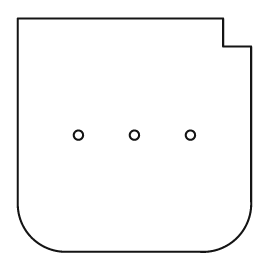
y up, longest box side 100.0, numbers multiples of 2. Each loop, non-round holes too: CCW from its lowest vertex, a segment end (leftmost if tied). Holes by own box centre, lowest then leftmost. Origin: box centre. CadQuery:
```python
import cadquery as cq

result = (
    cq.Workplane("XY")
    .moveTo(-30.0, -50.0)
    .lineTo(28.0, -50.0)
    .threePointArc((44.0, -44.0), (50.0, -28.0))
    .lineTo(50.0, 38.0)
    .lineTo(38.0, 38.0)
    .lineTo(38.0, 50.0)
    .lineTo(-50.0, 50.0)
    .lineTo(-50.0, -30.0)
    .threePointArc((-44.0, -44.0), (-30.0, -50.0))
    .close()
    .moveTo(-24.0, 0.0)
    .circle(2.0)
    .moveTo(0.0, 0.0)
    .circle(2.0)
    .moveTo(24.0, 0.0)
    .circle(2.0)
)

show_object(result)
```